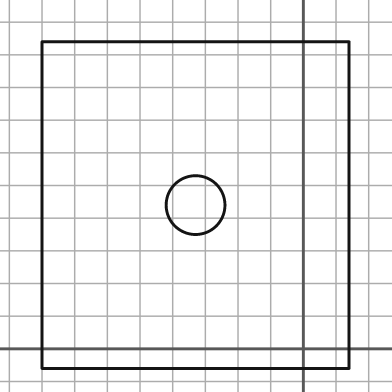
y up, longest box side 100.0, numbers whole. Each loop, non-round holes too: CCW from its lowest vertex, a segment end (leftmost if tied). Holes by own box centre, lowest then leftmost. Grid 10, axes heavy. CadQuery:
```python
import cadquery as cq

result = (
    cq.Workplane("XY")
    .moveTo(-80.0, -6.0)
    .lineTo(14.0, -6.0)
    .lineTo(14.0, 94.0)
    .lineTo(-80.0, 94.0)
    .close()
    .moveTo(-33.0, 44.0)
    .circle(9.0)
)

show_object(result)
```